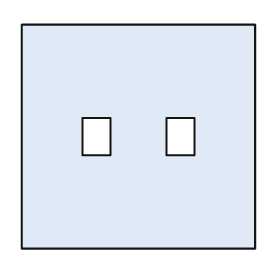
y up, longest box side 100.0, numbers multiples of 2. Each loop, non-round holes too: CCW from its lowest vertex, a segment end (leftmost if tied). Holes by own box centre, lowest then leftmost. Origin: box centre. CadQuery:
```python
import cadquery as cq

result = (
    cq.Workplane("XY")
    .moveTo(-50.0, -48.0)
    .lineTo(50.0, -48.0)
    .lineTo(50.0, 48.0)
    .lineTo(-50.0, 48.0)
    .close()
    .moveTo(-24.0, -8.0)
    .lineTo(-12.0, -8.0)
    .lineTo(-12.0, 8.0)
    .lineTo(-24.0, 8.0)
    .close()
    .moveTo(12.0, -8.0)
    .lineTo(24.0, -8.0)
    .lineTo(24.0, 8.0)
    .lineTo(12.0, 8.0)
    .close()
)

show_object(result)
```